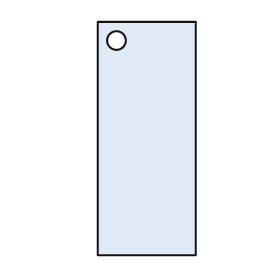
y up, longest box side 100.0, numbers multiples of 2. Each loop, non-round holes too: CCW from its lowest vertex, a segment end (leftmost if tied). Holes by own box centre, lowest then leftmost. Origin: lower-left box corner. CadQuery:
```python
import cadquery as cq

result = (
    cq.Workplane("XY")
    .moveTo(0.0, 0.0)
    .lineTo(42.0, 0.0)
    .lineTo(42.0, 100.0)
    .lineTo(0.0, 100.0)
    .close()
    .moveTo(8.0, 92.0)
    .circle(4.0)
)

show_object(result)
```